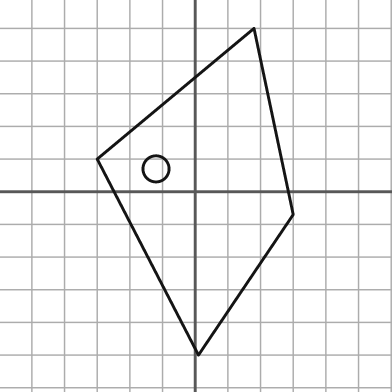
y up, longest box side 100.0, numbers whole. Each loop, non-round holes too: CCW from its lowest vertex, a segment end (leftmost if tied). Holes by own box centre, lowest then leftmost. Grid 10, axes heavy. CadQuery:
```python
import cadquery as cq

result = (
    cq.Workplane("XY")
    .moveTo(1.0, -50.0)
    .lineTo(30.0, -7.0)
    .lineTo(18.0, 50.0)
    .lineTo(-30.0, 10.0)
    .close()
    .moveTo(-12.0, 7.0)
    .circle(4.0)
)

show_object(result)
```